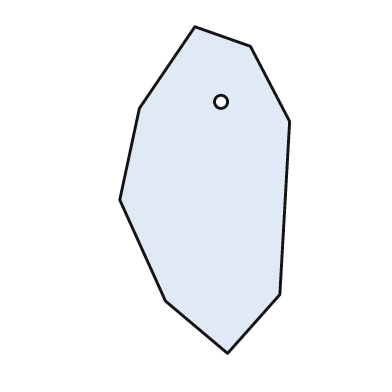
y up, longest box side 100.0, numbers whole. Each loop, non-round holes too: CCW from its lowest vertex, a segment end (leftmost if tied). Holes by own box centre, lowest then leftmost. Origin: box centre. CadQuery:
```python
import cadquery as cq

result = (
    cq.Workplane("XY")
    .moveTo(7.0, -50.0)
    .lineTo(23.0, -32.0)
    .lineTo(26.0, 21.0)
    .lineTo(14.0, 44.0)
    .lineTo(-3.0, 50.0)
    .lineTo(-20.0, 25.0)
    .lineTo(-26.0, -3.0)
    .lineTo(-12.0, -34.0)
    .close()
    .moveTo(5.0, 27.0)
    .circle(2.0)
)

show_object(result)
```